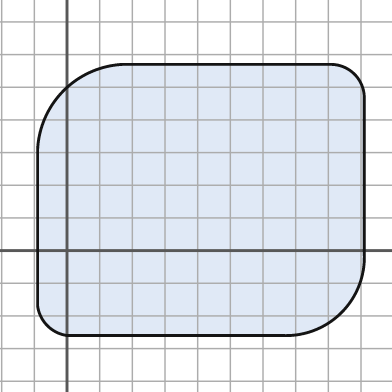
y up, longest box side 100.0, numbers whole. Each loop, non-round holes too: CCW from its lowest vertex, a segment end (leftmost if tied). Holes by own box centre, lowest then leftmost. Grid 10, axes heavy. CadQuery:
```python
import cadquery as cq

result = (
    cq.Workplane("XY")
    .moveTo(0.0, -26.0)
    .lineTo(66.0, -26.0)
    .threePointArc((84.0, -19.0), (91.0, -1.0))
    .lineTo(91.0, 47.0)
    .threePointArc((88.0, 54.0), (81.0, 57.0))
    .lineTo(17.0, 57.0)
    .threePointArc((-1.0, 49.0), (-9.0, 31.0))
    .lineTo(-9.0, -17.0)
    .threePointArc((-6.0, -23.0), (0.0, -26.0))
    .close()
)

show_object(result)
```